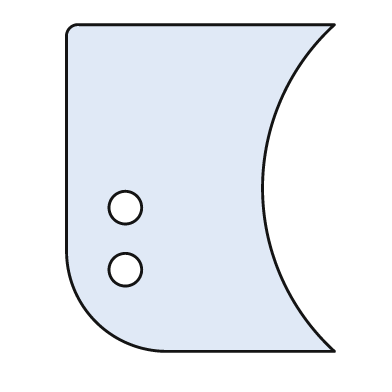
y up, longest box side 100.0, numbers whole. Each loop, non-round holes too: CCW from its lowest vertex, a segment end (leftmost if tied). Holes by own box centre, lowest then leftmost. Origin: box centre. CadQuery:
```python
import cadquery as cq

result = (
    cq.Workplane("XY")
    .moveTo(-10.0, -50.0)
    .lineTo(41.0, -50.0)
    .threePointArc((19.0, 0.0), (41.0, 50.0))
    .lineTo(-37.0, 50.0)
    .threePointArc((-40.0, 49.0), (-41.0, 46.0))
    .lineTo(-41.0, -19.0)
    .threePointArc((-32.0, -41.0), (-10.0, -50.0))
    .close()
    .moveTo(-23.0, -25.0)
    .circle(5.0)
    .moveTo(-23.0, -6.0)
    .circle(5.0)
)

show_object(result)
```